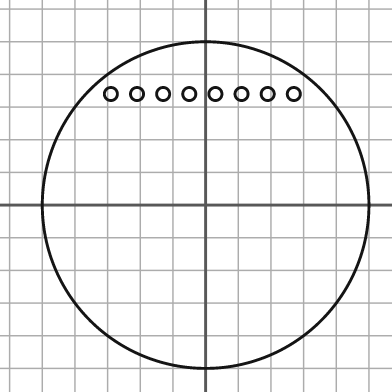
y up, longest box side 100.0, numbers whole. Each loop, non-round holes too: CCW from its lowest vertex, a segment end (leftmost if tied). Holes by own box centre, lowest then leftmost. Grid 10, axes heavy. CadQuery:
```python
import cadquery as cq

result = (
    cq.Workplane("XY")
    .moveTo(0.0, 0.0)
    .circle(50.0)
    .moveTo(-29.0, 34.0)
    .circle(2.0)
    .moveTo(-21.0, 34.0)
    .circle(2.0)
    .moveTo(-13.0, 34.0)
    .circle(2.0)
    .moveTo(-5.0, 34.0)
    .circle(2.0)
    .moveTo(3.0, 34.0)
    .circle(2.0)
    .moveTo(11.0, 34.0)
    .circle(2.0)
    .moveTo(19.0, 34.0)
    .circle(2.0)
    .moveTo(27.0, 34.0)
    .circle(2.0)
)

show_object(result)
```